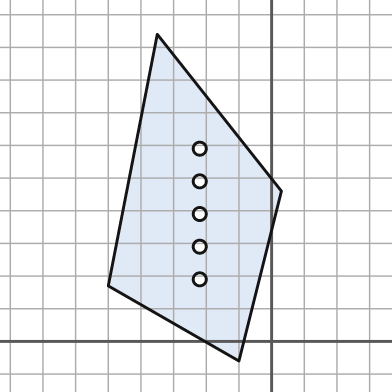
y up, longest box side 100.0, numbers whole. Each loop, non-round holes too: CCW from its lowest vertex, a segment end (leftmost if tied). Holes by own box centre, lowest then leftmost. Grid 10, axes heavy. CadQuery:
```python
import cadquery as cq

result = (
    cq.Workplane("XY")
    .moveTo(-10.0, -6.0)
    .lineTo(3.0, 46.0)
    .lineTo(-35.0, 94.0)
    .lineTo(-50.0, 17.0)
    .close()
    .moveTo(-22.0, 19.0)
    .circle(2.0)
    .moveTo(-22.0, 29.0)
    .circle(2.0)
    .moveTo(-22.0, 39.0)
    .circle(2.0)
    .moveTo(-22.0, 49.0)
    .circle(2.0)
    .moveTo(-22.0, 59.0)
    .circle(2.0)
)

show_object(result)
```